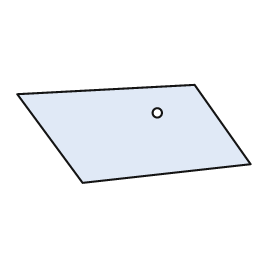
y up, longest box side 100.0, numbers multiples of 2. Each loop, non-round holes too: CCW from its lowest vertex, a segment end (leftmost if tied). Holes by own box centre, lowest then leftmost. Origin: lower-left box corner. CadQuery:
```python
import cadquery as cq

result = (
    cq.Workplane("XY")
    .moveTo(28.0, 0.0)
    .lineTo(100.0, 8.0)
    .lineTo(76.0, 42.0)
    .lineTo(0.0, 38.0)
    .close()
    .moveTo(60.0, 30.0)
    .circle(2.0)
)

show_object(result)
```